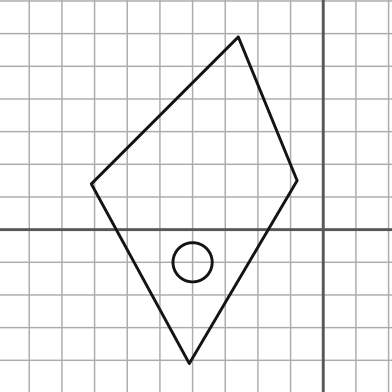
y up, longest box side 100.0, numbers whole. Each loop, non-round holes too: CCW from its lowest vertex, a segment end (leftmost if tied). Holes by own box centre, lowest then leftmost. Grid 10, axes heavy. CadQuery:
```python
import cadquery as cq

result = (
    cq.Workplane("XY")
    .moveTo(-41.0, -41.0)
    .lineTo(-8.0, 15.0)
    .lineTo(-26.0, 59.0)
    .lineTo(-71.0, 14.0)
    .close()
    .moveTo(-40.0, -10.0)
    .circle(6.0)
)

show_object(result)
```